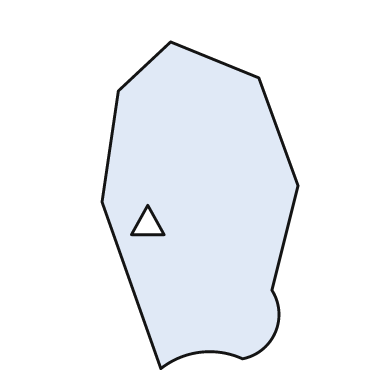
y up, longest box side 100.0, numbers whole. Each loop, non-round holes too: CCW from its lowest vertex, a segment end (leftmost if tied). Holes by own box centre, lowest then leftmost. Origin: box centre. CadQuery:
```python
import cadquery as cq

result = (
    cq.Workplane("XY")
    .moveTo(-12.0, -50.0)
    .threePointArc((0.0, -45.0), (13.0, -47.0))
    .threePointArc((23.0, -39.0), (22.0, -26.0))
    .lineTo(30.0, 6.0)
    .lineTo(18.0, 39.0)
    .lineTo(-9.0, 50.0)
    .lineTo(-25.0, 35.0)
    .lineTo(-30.0, 1.0)
    .close()
    .moveTo(-21.0, -9.0)
    .lineTo(-11.0, -9.0)
    .lineTo(-16.0, 0.0)
    .close()
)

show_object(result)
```